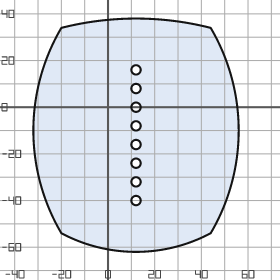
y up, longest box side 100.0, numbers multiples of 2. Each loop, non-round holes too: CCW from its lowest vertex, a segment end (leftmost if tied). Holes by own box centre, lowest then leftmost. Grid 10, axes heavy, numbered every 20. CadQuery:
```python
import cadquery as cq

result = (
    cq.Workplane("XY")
    .moveTo(-20.0, -54.0)
    .threePointArc((12.0, -62.0), (44.0, -54.0))
    .threePointArc((56.0, -10.0), (44.0, 34.0))
    .threePointArc((12.0, 38.0), (-20.0, 34.0))
    .threePointArc((-32.0, -10.0), (-20.0, -54.0))
    .close()
    .moveTo(12.0, -40.0)
    .circle(2.0)
    .moveTo(12.0, -32.0)
    .circle(2.0)
    .moveTo(12.0, -24.0)
    .circle(2.0)
    .moveTo(12.0, -16.0)
    .circle(2.0)
    .moveTo(12.0, -8.0)
    .circle(2.0)
    .moveTo(12.0, 0.0)
    .circle(2.0)
    .moveTo(12.0, 8.0)
    .circle(2.0)
    .moveTo(12.0, 16.0)
    .circle(2.0)
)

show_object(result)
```